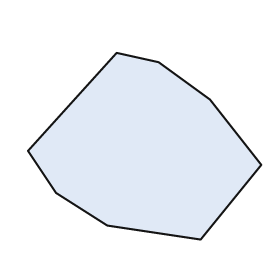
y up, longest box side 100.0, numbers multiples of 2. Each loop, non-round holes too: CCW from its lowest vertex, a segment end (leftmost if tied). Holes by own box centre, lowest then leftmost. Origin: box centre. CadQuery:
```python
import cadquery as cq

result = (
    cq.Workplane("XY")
    .moveTo(24.0, -40.0)
    .lineTo(50.0, -8.0)
    .lineTo(28.0, 20.0)
    .lineTo(6.0, 36.0)
    .lineTo(-12.0, 40.0)
    .lineTo(-50.0, -2.0)
    .lineTo(-38.0, -20.0)
    .lineTo(-16.0, -34.0)
    .close()
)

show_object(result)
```